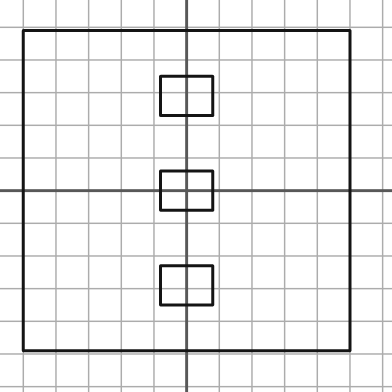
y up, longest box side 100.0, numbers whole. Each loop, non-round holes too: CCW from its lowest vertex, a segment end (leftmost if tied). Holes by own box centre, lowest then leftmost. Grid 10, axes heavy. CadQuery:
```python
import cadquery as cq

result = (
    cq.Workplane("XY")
    .moveTo(-50.0, -49.0)
    .lineTo(50.0, -49.0)
    .lineTo(50.0, 49.0)
    .lineTo(-50.0, 49.0)
    .close()
    .moveTo(-8.0, -35.0)
    .lineTo(8.0, -35.0)
    .lineTo(8.0, -23.0)
    .lineTo(-8.0, -23.0)
    .close()
    .moveTo(-8.0, -6.0)
    .lineTo(8.0, -6.0)
    .lineTo(8.0, 6.0)
    .lineTo(-8.0, 6.0)
    .close()
    .moveTo(-8.0, 23.0)
    .lineTo(8.0, 23.0)
    .lineTo(8.0, 35.0)
    .lineTo(-8.0, 35.0)
    .close()
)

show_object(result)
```